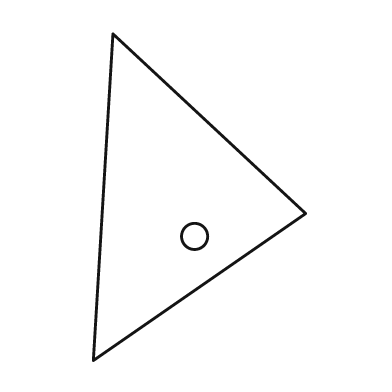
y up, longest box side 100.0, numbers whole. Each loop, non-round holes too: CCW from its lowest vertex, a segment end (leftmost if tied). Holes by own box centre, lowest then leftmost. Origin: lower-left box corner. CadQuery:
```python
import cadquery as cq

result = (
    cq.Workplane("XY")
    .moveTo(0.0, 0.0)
    .lineTo(65.0, 45.0)
    .lineTo(6.0, 100.0)
    .close()
    .moveTo(31.0, 38.0)
    .circle(4.0)
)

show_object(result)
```